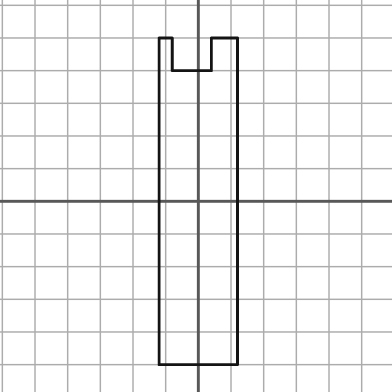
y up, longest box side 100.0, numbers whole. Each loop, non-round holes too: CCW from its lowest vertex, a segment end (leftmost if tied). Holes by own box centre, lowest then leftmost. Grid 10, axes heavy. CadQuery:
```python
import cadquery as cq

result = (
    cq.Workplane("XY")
    .moveTo(-12.0, -50.0)
    .lineTo(12.0, -50.0)
    .lineTo(12.0, 50.0)
    .lineTo(4.0, 50.0)
    .lineTo(4.0, 40.0)
    .lineTo(-8.0, 40.0)
    .lineTo(-8.0, 50.0)
    .lineTo(-12.0, 50.0)
    .close()
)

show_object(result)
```